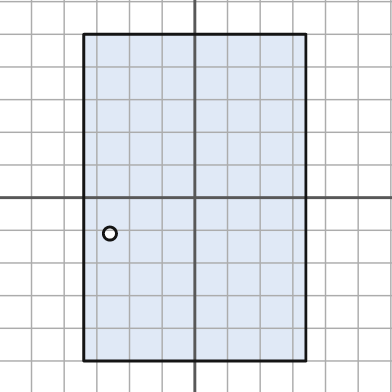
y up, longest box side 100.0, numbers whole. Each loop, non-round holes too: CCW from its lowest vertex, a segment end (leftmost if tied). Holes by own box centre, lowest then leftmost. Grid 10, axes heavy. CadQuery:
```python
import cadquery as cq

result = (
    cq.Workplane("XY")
    .moveTo(-34.0, -50.0)
    .lineTo(34.0, -50.0)
    .lineTo(34.0, 50.0)
    .lineTo(-34.0, 50.0)
    .close()
    .moveTo(-26.0, -11.0)
    .circle(2.0)
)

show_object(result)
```